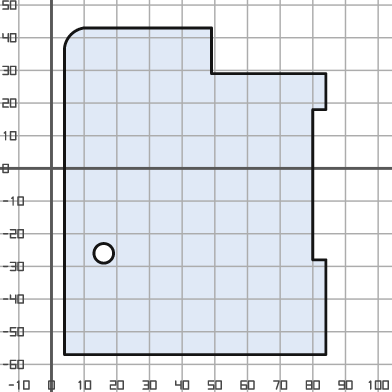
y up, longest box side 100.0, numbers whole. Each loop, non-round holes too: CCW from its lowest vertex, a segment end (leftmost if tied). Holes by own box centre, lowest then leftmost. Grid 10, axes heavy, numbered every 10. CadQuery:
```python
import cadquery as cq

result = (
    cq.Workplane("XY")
    .moveTo(4.0, -57.0)
    .lineTo(84.0, -57.0)
    .lineTo(84.0, -28.0)
    .lineTo(80.0, -28.0)
    .lineTo(80.0, 18.0)
    .lineTo(84.0, 18.0)
    .lineTo(84.0, 29.0)
    .lineTo(49.0, 29.0)
    .lineTo(49.0, 43.0)
    .lineTo(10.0, 43.0)
    .threePointArc((6.0, 41.0), (4.0, 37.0))
    .close()
    .moveTo(16.0, -26.0)
    .circle(3.0)
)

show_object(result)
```